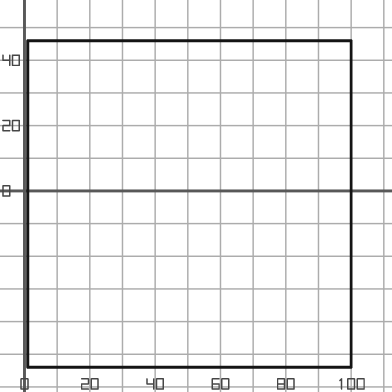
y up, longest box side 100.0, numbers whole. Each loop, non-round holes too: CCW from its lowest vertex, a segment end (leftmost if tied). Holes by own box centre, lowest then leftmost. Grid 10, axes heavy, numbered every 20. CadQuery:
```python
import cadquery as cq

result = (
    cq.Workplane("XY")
    .moveTo(1.0, -54.0)
    .lineTo(100.0, -54.0)
    .lineTo(100.0, 46.0)
    .lineTo(1.0, 46.0)
    .close()
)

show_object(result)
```